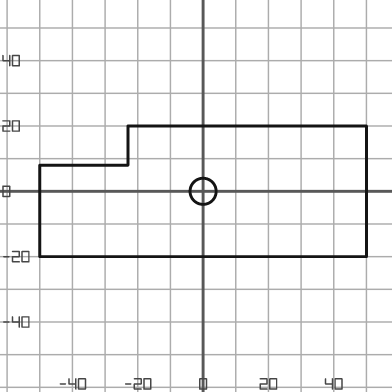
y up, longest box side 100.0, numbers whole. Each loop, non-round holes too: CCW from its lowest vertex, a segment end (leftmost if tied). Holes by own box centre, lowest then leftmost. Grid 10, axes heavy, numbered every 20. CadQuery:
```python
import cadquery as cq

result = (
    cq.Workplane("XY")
    .moveTo(-50.0, -20.0)
    .lineTo(50.0, -20.0)
    .lineTo(50.0, 20.0)
    .lineTo(-23.0, 20.0)
    .lineTo(-23.0, 8.0)
    .lineTo(-50.0, 8.0)
    .close()
    .moveTo(0.0, 0.0)
    .circle(4.0)
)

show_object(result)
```